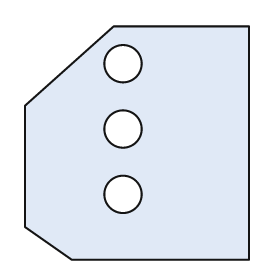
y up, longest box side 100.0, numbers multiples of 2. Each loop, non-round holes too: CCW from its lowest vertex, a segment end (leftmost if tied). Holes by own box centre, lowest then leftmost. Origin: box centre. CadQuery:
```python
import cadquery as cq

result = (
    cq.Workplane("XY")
    .moveTo(-28.0, -50.0)
    .lineTo(48.0, -50.0)
    .lineTo(48.0, 50.0)
    .lineTo(-10.0, 50.0)
    .lineTo(-48.0, 16.0)
    .lineTo(-48.0, -36.0)
    .close()
    .moveTo(-6.0, -22.0)
    .circle(8.0)
    .moveTo(-6.0, 6.0)
    .circle(8.0)
    .moveTo(-6.0, 34.0)
    .circle(8.0)
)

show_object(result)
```